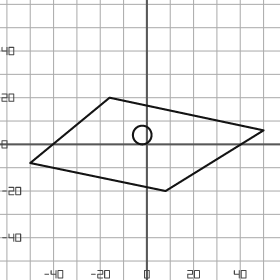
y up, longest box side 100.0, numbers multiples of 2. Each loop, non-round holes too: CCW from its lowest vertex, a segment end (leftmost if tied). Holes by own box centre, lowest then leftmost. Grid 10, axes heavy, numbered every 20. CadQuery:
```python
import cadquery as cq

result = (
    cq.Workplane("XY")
    .moveTo(8.0, -20.0)
    .lineTo(50.0, 6.0)
    .lineTo(-16.0, 20.0)
    .lineTo(-50.0, -8.0)
    .close()
    .moveTo(-2.0, 4.0)
    .circle(4.0)
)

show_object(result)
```